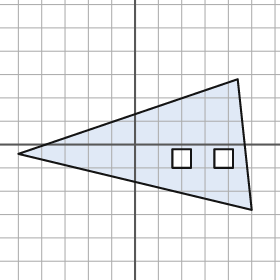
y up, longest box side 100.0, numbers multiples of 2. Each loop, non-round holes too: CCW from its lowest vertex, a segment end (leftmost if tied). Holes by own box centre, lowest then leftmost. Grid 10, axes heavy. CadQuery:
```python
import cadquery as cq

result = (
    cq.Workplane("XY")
    .moveTo(50.0, -28.0)
    .lineTo(44.0, 28.0)
    .lineTo(-50.0, -4.0)
    .close()
    .moveTo(16.0, -10.0)
    .lineTo(24.0, -10.0)
    .lineTo(24.0, -2.0)
    .lineTo(16.0, -2.0)
    .close()
    .moveTo(34.0, -10.0)
    .lineTo(42.0, -10.0)
    .lineTo(42.0, -2.0)
    .lineTo(34.0, -2.0)
    .close()
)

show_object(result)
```